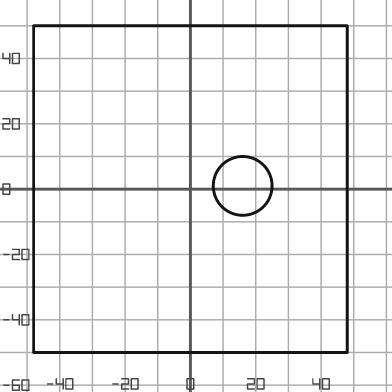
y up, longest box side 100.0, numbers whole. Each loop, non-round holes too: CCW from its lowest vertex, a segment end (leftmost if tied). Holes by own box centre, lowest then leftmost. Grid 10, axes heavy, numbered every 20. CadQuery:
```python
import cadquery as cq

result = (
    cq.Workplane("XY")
    .moveTo(-48.0, -50.0)
    .lineTo(48.0, -50.0)
    .lineTo(48.0, 50.0)
    .lineTo(-48.0, 50.0)
    .close()
    .moveTo(16.0, 1.0)
    .circle(9.0)
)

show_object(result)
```